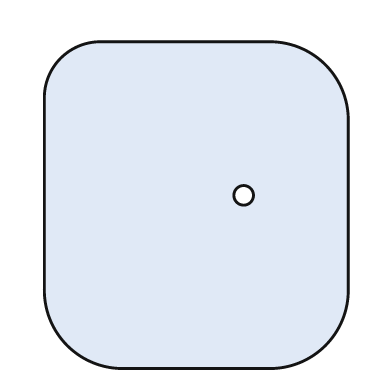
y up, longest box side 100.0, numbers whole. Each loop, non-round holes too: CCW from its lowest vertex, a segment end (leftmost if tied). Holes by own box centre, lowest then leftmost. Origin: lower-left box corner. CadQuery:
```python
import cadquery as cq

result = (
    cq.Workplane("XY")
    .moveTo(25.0, 0.0)
    .lineTo(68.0, 0.0)
    .threePointArc((86.0, 7.0), (93.0, 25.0))
    .lineTo(93.0, 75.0)
    .threePointArc((86.0, 93.0), (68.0, 100.0))
    .lineTo(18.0, 100.0)
    .threePointArc((5.0, 95.0), (0.0, 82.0))
    .lineTo(0.0, 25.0)
    .threePointArc((7.0, 7.0), (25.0, 0.0))
    .close()
    .moveTo(61.0, 53.0)
    .circle(3.0)
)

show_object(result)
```